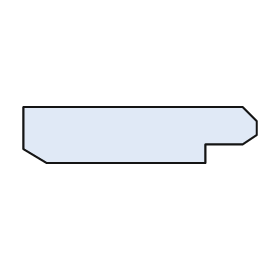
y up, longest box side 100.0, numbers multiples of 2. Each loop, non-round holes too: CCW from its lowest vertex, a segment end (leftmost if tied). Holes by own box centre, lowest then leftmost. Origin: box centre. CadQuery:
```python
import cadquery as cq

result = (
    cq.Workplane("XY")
    .moveTo(-40.0, -12.0)
    .lineTo(28.0, -12.0)
    .lineTo(28.0, -4.0)
    .lineTo(44.0, -4.0)
    .lineTo(50.0, 0.0)
    .lineTo(50.0, 6.0)
    .lineTo(44.0, 12.0)
    .lineTo(-50.0, 12.0)
    .lineTo(-50.0, -6.0)
    .close()
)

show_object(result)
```